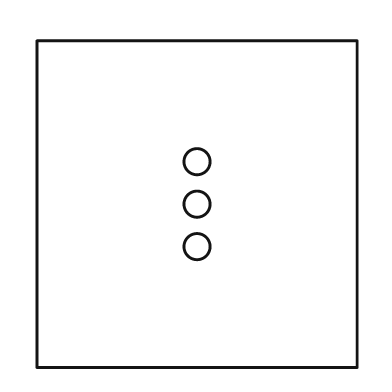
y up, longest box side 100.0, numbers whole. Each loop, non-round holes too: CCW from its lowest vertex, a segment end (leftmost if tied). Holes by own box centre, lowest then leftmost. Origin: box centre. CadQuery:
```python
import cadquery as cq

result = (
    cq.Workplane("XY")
    .moveTo(-49.0, -50.0)
    .lineTo(49.0, -50.0)
    .lineTo(49.0, 50.0)
    .lineTo(-49.0, 50.0)
    .close()
    .moveTo(0.0, -13.0)
    .circle(4.0)
    .moveTo(0.0, 0.0)
    .circle(4.0)
    .moveTo(0.0, 13.0)
    .circle(4.0)
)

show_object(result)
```